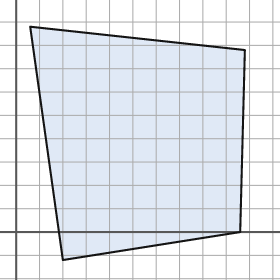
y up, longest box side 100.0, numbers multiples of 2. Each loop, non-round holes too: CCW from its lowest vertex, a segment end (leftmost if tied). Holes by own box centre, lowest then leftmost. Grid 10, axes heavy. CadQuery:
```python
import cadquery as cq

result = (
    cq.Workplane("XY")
    .moveTo(20.0, -12.0)
    .lineTo(96.0, 0.0)
    .lineTo(98.0, 78.0)
    .lineTo(6.0, 88.0)
    .close()
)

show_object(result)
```